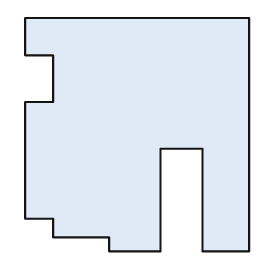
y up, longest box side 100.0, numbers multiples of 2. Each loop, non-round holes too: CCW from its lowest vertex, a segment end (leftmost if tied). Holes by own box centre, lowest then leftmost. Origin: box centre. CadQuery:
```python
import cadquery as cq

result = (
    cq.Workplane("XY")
    .moveTo(-12.0, -50.0)
    .lineTo(10.0, -50.0)
    .lineTo(10.0, -6.0)
    .lineTo(28.0, -6.0)
    .lineTo(28.0, -50.0)
    .lineTo(48.0, -50.0)
    .lineTo(48.0, 50.0)
    .lineTo(-48.0, 50.0)
    .lineTo(-48.0, 34.0)
    .lineTo(-36.0, 34.0)
    .lineTo(-36.0, 14.0)
    .lineTo(-48.0, 14.0)
    .lineTo(-48.0, -36.0)
    .lineTo(-36.0, -36.0)
    .lineTo(-36.0, -44.0)
    .lineTo(-12.0, -44.0)
    .close()
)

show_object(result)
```